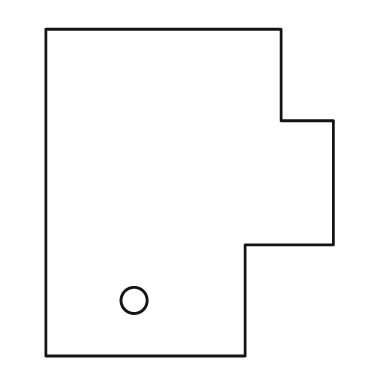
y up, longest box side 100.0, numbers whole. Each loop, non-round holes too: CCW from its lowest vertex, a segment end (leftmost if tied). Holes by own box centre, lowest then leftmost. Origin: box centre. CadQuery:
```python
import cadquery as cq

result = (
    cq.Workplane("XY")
    .moveTo(-44.0, -50.0)
    .lineTo(17.0, -50.0)
    .lineTo(17.0, -16.0)
    .lineTo(44.0, -16.0)
    .lineTo(44.0, 22.0)
    .lineTo(28.0, 22.0)
    .lineTo(28.0, 50.0)
    .lineTo(-44.0, 50.0)
    .close()
    .moveTo(-17.0, -33.0)
    .circle(4.0)
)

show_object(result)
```